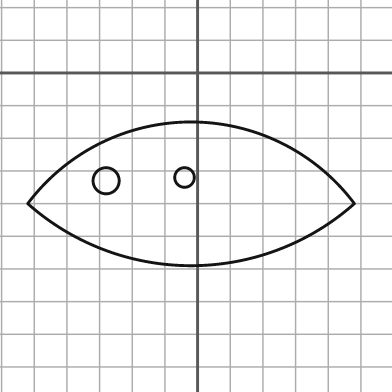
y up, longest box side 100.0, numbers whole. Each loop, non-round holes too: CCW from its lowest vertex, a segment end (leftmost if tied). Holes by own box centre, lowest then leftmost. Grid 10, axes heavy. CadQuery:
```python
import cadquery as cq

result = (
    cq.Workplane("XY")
    .moveTo(-52.0, -40.0)
    .threePointArc((-2.0, -59.0), (48.0, -40.0))
    .threePointArc((-2.0, -15.0), (-52.0, -40.0))
    .close()
    .moveTo(-28.0, -33.0)
    .circle(4.0)
    .moveTo(-4.0, -32.0)
    .circle(3.0)
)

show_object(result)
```